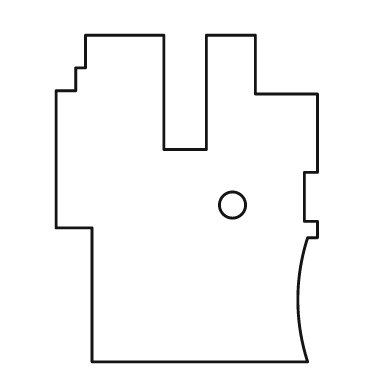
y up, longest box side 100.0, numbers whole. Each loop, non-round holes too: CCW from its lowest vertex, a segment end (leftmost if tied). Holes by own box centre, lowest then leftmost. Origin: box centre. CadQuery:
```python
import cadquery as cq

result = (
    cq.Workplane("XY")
    .moveTo(-29.0, -50.0)
    .lineTo(37.0, -50.0)
    .threePointArc((34.0, -31.0), (37.0, -12.0))
    .lineTo(40.0, -12.0)
    .lineTo(40.0, -7.0)
    .lineTo(36.0, -7.0)
    .lineTo(36.0, 8.0)
    .lineTo(40.0, 8.0)
    .lineTo(40.0, 32.0)
    .lineTo(21.0, 32.0)
    .lineTo(21.0, 50.0)
    .lineTo(6.0, 50.0)
    .lineTo(6.0, 15.0)
    .lineTo(-7.0, 15.0)
    .lineTo(-7.0, 50.0)
    .lineTo(-31.0, 50.0)
    .lineTo(-31.0, 40.0)
    .lineTo(-34.0, 40.0)
    .lineTo(-34.0, 33.0)
    .lineTo(-40.0, 33.0)
    .lineTo(-40.0, -9.0)
    .lineTo(-29.0, -9.0)
    .close()
    .moveTo(14.0, -2.0)
    .circle(4.0)
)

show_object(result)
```